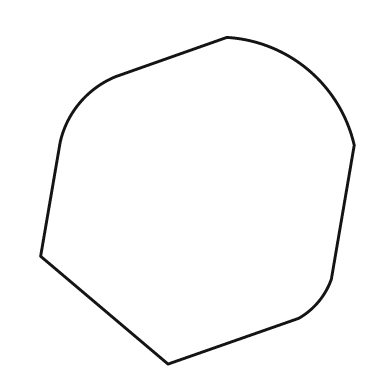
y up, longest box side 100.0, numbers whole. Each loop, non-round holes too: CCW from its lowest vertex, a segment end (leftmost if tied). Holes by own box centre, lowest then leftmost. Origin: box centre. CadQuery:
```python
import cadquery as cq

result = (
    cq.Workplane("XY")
    .moveTo(-9.0, -50.0)
    .lineTo(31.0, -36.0)
    .threePointArc((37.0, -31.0), (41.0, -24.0))
    .lineTo(48.0, 17.0)
    .threePointArc((34.0, 40.0), (9.0, 50.0))
    .lineTo(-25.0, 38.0)
    .threePointArc((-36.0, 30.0), (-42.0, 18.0))
    .lineTo(-48.0, -17.0)
    .close()
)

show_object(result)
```